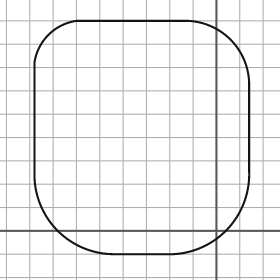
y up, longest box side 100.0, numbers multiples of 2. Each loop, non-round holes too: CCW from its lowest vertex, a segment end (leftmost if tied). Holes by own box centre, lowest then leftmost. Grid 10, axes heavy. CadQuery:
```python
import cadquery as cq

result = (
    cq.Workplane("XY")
    .moveTo(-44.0, -10.0)
    .lineTo(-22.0, -10.0)
    .threePointArc((4.0, 0.0), (14.0, 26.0))
    .lineTo(14.0, 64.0)
    .threePointArc((6.0, 82.0), (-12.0, 90.0))
    .lineTo(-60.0, 90.0)
    .threePointArc((-72.0, 84.0), (-78.0, 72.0))
    .lineTo(-78.0, 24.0)
    .threePointArc((-68.0, 0.0), (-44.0, -10.0))
    .close()
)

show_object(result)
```